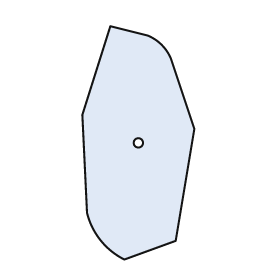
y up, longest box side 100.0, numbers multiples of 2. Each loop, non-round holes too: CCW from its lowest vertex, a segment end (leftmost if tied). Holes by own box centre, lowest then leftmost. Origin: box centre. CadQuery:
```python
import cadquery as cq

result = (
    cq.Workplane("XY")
    .moveTo(-6.0, -50.0)
    .lineTo(16.0, -42.0)
    .lineTo(24.0, 6.0)
    .lineTo(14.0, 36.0)
    .threePointArc((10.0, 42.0), (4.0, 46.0))
    .lineTo(-12.0, 50.0)
    .lineTo(-24.0, 12.0)
    .lineTo(-22.0, -30.0)
    .threePointArc((-16.0, -42.0), (-6.0, -50.0))
    .close()
    .moveTo(0.0, 0.0)
    .circle(2.0)
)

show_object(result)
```